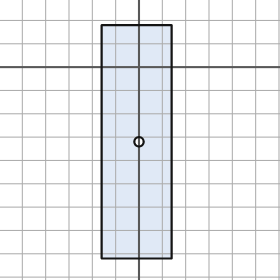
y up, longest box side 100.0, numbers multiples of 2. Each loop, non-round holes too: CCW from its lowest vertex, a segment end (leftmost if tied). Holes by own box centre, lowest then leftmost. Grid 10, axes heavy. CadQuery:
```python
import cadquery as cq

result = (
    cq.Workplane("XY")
    .moveTo(-16.0, -82.0)
    .lineTo(14.0, -82.0)
    .lineTo(14.0, 18.0)
    .lineTo(-16.0, 18.0)
    .close()
    .moveTo(0.0, -32.0)
    .circle(2.0)
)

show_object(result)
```